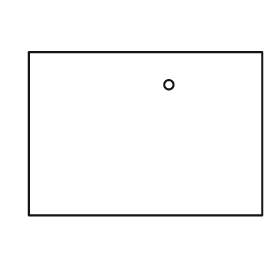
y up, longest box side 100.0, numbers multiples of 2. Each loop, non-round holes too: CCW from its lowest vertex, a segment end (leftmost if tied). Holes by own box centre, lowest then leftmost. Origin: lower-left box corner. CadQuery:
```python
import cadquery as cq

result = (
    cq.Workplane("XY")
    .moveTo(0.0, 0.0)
    .lineTo(100.0, 0.0)
    .lineTo(100.0, 70.0)
    .lineTo(0.0, 70.0)
    .close()
    .moveTo(60.0, 56.0)
    .circle(2.0)
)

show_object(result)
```